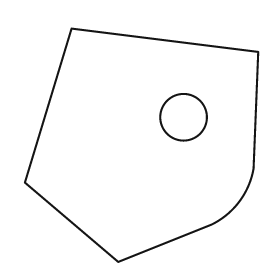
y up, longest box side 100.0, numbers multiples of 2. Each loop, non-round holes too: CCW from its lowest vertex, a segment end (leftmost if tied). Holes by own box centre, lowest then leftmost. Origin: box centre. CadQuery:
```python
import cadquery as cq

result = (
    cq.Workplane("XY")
    .moveTo(-10.0, -50.0)
    .lineTo(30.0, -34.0)
    .threePointArc((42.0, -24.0), (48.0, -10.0))
    .lineTo(50.0, 40.0)
    .lineTo(-30.0, 50.0)
    .lineTo(-50.0, -16.0)
    .close()
    .moveTo(18.0, 12.0)
    .circle(10.0)
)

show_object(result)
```